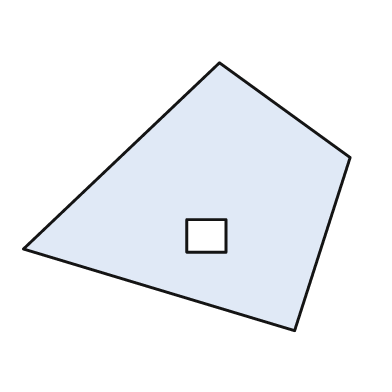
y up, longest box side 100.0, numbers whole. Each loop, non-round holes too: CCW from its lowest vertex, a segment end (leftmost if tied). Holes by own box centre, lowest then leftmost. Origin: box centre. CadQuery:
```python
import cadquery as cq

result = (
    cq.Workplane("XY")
    .moveTo(33.0, -41.0)
    .lineTo(50.0, 12.0)
    .lineTo(10.0, 41.0)
    .lineTo(-50.0, -16.0)
    .close()
    .moveTo(0.0, -17.0)
    .lineTo(12.0, -17.0)
    .lineTo(12.0, -7.0)
    .lineTo(0.0, -7.0)
    .close()
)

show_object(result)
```